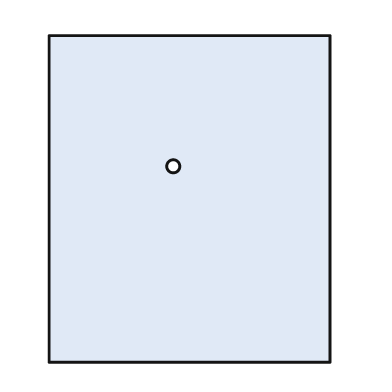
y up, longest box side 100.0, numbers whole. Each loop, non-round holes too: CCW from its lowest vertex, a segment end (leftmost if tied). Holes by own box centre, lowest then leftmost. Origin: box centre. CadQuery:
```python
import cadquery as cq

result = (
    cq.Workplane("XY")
    .moveTo(-43.0, -50.0)
    .lineTo(43.0, -50.0)
    .lineTo(43.0, 50.0)
    .lineTo(-43.0, 50.0)
    .close()
    .moveTo(-5.0, 10.0)
    .circle(2.0)
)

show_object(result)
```